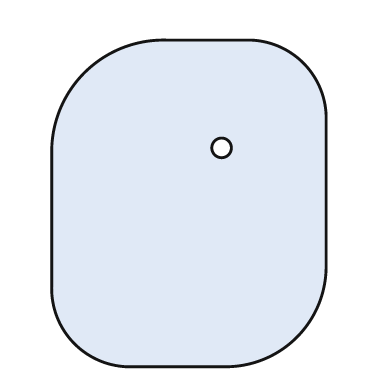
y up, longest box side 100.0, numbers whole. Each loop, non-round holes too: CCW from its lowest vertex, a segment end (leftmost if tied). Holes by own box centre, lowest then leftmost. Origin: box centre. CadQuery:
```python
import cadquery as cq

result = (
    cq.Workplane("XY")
    .moveTo(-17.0, -50.0)
    .lineTo(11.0, -50.0)
    .threePointArc((33.0, -41.0), (42.0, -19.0))
    .lineTo(42.0, 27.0)
    .threePointArc((35.0, 43.0), (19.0, 50.0))
    .lineTo(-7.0, 50.0)
    .threePointArc((-32.0, 40.0), (-42.0, 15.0))
    .lineTo(-42.0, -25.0)
    .threePointArc((-35.0, -43.0), (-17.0, -50.0))
    .close()
    .moveTo(10.0, 17.0)
    .circle(3.0)
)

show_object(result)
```